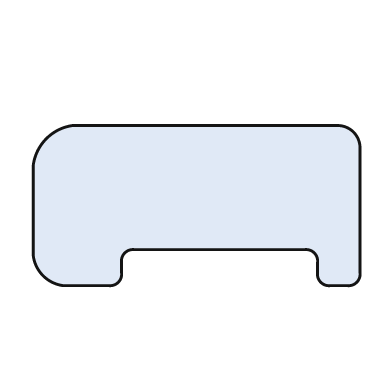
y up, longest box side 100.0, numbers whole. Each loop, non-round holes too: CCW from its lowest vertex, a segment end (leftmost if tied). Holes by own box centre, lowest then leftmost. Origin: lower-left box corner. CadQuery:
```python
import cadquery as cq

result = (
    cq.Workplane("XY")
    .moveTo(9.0, 0.0)
    .lineTo(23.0, 0.0)
    .threePointArc((26.0, 1.0), (27.0, 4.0))
    .lineTo(27.0, 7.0)
    .threePointArc((28.0, 10.0), (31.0, 11.0))
    .lineTo(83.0, 11.0)
    .threePointArc((86.0, 10.0), (87.0, 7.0))
    .lineTo(87.0, 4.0)
    .threePointArc((88.0, 1.0), (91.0, 0.0))
    .lineTo(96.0, 0.0)
    .threePointArc((99.0, 1.0), (100.0, 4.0))
    .lineTo(100.0, 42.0)
    .threePointArc((98.0, 47.0), (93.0, 49.0))
    .lineTo(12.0, 49.0)
    .threePointArc((4.0, 45.0), (0.0, 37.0))
    .lineTo(0.0, 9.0)
    .threePointArc((3.0, 3.0), (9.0, 0.0))
    .close()
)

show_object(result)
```